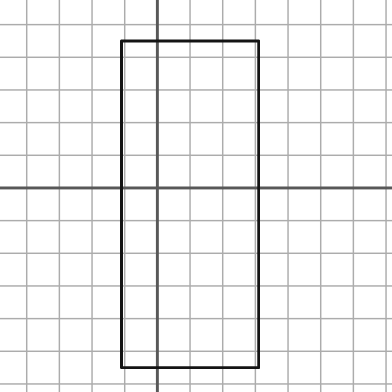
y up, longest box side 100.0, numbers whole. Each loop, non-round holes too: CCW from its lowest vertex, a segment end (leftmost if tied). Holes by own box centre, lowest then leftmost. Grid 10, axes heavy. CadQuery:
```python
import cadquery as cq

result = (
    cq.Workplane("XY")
    .moveTo(-11.0, -55.0)
    .lineTo(31.0, -55.0)
    .lineTo(31.0, 45.0)
    .lineTo(-11.0, 45.0)
    .close()
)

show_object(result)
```